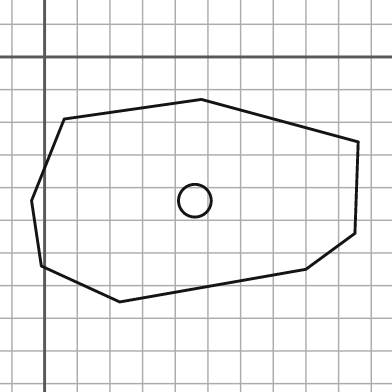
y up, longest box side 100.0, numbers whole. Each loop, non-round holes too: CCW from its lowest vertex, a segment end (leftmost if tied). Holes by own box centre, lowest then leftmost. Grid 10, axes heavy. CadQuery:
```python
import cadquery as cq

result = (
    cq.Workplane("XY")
    .moveTo(23.0, -75.0)
    .lineTo(80.0, -65.0)
    .lineTo(95.0, -54.0)
    .lineTo(96.0, -26.0)
    .lineTo(48.0, -13.0)
    .lineTo(6.0, -19.0)
    .lineTo(-4.0, -44.0)
    .lineTo(-1.0, -64.0)
    .close()
    .moveTo(46.0, -44.0)
    .circle(5.0)
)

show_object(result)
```